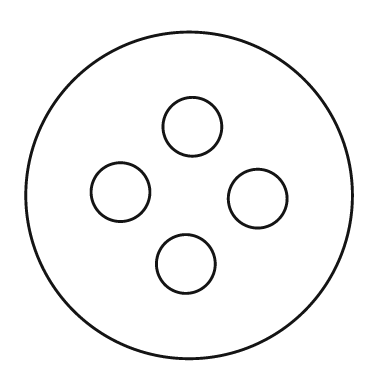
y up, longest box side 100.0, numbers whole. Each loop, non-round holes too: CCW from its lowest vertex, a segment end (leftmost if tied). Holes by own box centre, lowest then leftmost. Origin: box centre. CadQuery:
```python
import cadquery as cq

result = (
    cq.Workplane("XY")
    .moveTo(0.0, 0.0)
    .circle(50.0)
    .moveTo(-1.0, -21.0)
    .circle(9.0)
    .moveTo(21.0, -1.0)
    .circle(9.0)
    .moveTo(-21.0, 1.0)
    .circle(9.0)
    .moveTo(1.0, 21.0)
    .circle(9.0)
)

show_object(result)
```